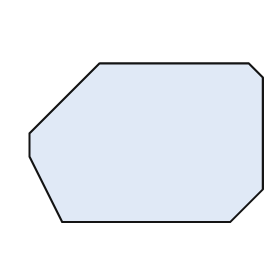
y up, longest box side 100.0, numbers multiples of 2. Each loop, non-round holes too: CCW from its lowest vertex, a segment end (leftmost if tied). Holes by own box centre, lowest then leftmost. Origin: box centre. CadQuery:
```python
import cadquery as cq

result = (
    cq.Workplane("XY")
    .moveTo(-36.0, -34.0)
    .lineTo(36.0, -34.0)
    .lineTo(50.0, -20.0)
    .lineTo(50.0, 28.0)
    .lineTo(44.0, 34.0)
    .lineTo(-20.0, 34.0)
    .lineTo(-50.0, 4.0)
    .lineTo(-50.0, -6.0)
    .close()
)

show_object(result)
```